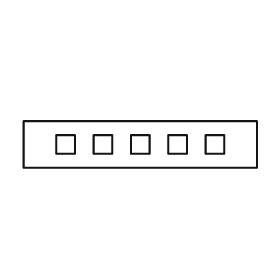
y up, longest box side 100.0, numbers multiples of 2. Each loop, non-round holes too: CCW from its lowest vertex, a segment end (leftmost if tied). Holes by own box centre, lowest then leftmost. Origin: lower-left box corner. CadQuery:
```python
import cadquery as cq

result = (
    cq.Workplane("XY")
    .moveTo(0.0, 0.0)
    .lineTo(100.0, 0.0)
    .lineTo(100.0, 20.0)
    .lineTo(0.0, 20.0)
    .close()
    .moveTo(14.0, 6.0)
    .lineTo(22.0, 6.0)
    .lineTo(22.0, 14.0)
    .lineTo(14.0, 14.0)
    .close()
    .moveTo(30.0, 6.0)
    .lineTo(38.0, 6.0)
    .lineTo(38.0, 14.0)
    .lineTo(30.0, 14.0)
    .close()
    .moveTo(46.0, 6.0)
    .lineTo(54.0, 6.0)
    .lineTo(54.0, 14.0)
    .lineTo(46.0, 14.0)
    .close()
    .moveTo(62.0, 6.0)
    .lineTo(70.0, 6.0)
    .lineTo(70.0, 14.0)
    .lineTo(62.0, 14.0)
    .close()
    .moveTo(78.0, 6.0)
    .lineTo(86.0, 6.0)
    .lineTo(86.0, 14.0)
    .lineTo(78.0, 14.0)
    .close()
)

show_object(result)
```